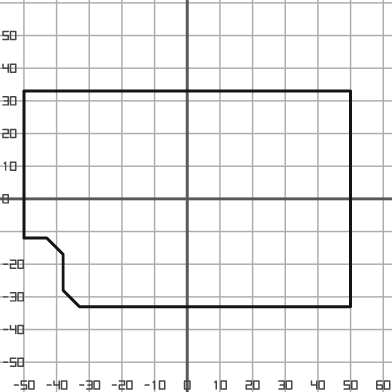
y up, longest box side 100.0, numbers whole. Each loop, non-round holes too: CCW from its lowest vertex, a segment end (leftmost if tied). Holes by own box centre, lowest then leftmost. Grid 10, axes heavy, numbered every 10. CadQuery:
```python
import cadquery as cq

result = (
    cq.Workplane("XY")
    .moveTo(-33.0, -33.0)
    .lineTo(50.0, -33.0)
    .lineTo(50.0, 33.0)
    .lineTo(-50.0, 33.0)
    .lineTo(-50.0, -12.0)
    .lineTo(-43.0, -12.0)
    .lineTo(-38.0, -17.0)
    .lineTo(-38.0, -28.0)
    .close()
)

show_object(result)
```